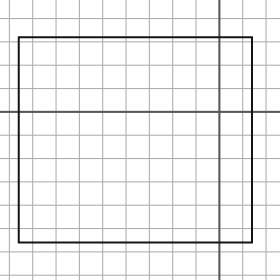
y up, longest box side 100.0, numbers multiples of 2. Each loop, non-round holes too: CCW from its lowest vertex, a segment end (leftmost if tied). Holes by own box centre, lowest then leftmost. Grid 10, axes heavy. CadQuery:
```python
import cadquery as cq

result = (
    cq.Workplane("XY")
    .moveTo(-86.0, -56.0)
    .lineTo(14.0, -56.0)
    .lineTo(14.0, 32.0)
    .lineTo(-86.0, 32.0)
    .close()
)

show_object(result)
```